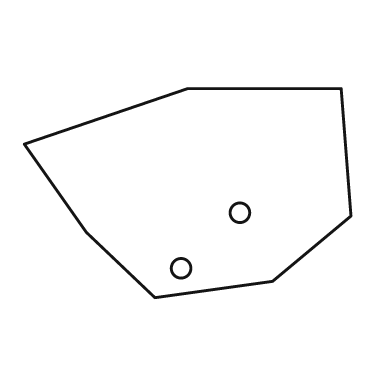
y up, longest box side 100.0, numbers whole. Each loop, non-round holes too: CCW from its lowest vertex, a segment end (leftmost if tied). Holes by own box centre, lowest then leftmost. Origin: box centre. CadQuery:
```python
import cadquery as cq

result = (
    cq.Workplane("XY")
    .moveTo(-10.0, -32.0)
    .lineTo(26.0, -27.0)
    .lineTo(50.0, -7.0)
    .lineTo(47.0, 32.0)
    .lineTo(0.0, 32.0)
    .lineTo(-50.0, 15.0)
    .lineTo(-31.0, -12.0)
    .close()
    .moveTo(-2.0, -23.0)
    .circle(3.0)
    .moveTo(16.0, -6.0)
    .circle(3.0)
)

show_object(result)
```